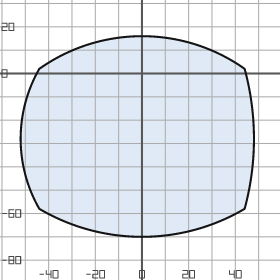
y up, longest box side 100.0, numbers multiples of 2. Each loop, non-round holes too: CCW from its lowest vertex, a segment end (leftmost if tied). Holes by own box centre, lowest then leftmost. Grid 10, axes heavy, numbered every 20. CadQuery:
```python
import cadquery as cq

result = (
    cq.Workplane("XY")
    .moveTo(-44.0, -58.0)
    .threePointArc((0.0, -70.0), (44.0, -58.0))
    .threePointArc((48.0, -28.0), (44.0, 2.0))
    .threePointArc((0.0, 16.0), (-44.0, 2.0))
    .threePointArc((-52.0, -28.0), (-44.0, -58.0))
    .close()
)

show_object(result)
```